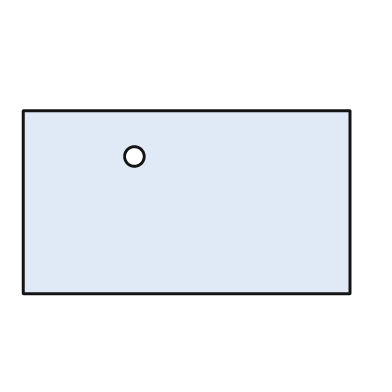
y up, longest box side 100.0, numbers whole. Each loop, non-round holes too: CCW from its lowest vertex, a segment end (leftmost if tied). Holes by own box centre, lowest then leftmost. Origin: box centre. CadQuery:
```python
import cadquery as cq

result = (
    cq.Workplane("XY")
    .moveTo(-50.0, -28.0)
    .lineTo(50.0, -28.0)
    .lineTo(50.0, 28.0)
    .lineTo(-50.0, 28.0)
    .close()
    .moveTo(-16.0, 14.0)
    .circle(3.0)
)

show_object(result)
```